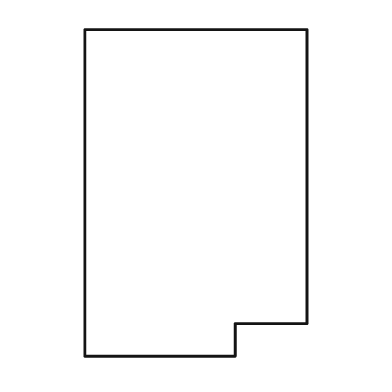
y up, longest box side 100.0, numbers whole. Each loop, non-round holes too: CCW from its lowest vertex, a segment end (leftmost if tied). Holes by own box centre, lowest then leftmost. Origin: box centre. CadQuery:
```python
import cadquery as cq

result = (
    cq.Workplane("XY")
    .moveTo(-34.0, -50.0)
    .lineTo(12.0, -50.0)
    .lineTo(12.0, -40.0)
    .lineTo(34.0, -40.0)
    .lineTo(34.0, 50.0)
    .lineTo(-34.0, 50.0)
    .close()
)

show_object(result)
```